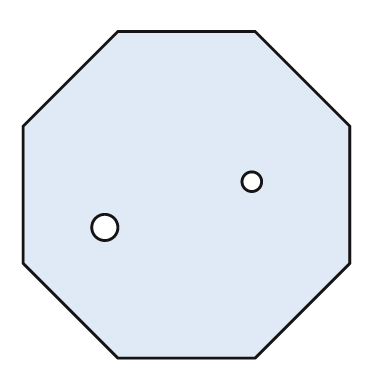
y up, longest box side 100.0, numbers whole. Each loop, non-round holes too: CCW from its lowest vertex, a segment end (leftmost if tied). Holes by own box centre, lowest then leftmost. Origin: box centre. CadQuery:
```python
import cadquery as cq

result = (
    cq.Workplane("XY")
    .moveTo(-21.0, -50.0)
    .lineTo(21.0, -50.0)
    .lineTo(50.0, -21.0)
    .lineTo(50.0, 21.0)
    .lineTo(21.0, 50.0)
    .lineTo(-21.0, 50.0)
    .lineTo(-50.0, 21.0)
    .lineTo(-50.0, -21.0)
    .close()
    .moveTo(-25.0, -10.0)
    .circle(4.0)
    .moveTo(20.0, 4.0)
    .circle(3.0)
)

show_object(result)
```